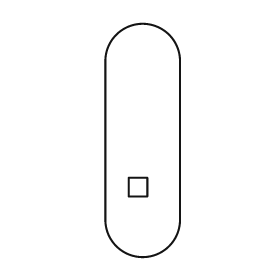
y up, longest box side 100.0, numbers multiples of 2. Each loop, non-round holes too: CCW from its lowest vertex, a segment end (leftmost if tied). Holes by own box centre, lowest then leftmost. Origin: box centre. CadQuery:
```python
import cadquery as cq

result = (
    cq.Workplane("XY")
    .moveTo(-16.0, -34.0)
    .threePointArc((0.0, -50.0), (16.0, -34.0))
    .lineTo(16.0, 34.0)
    .threePointArc((0.0, 50.0), (-16.0, 34.0))
    .close()
    .moveTo(-6.0, -24.0)
    .lineTo(2.0, -24.0)
    .lineTo(2.0, -16.0)
    .lineTo(-6.0, -16.0)
    .close()
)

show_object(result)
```